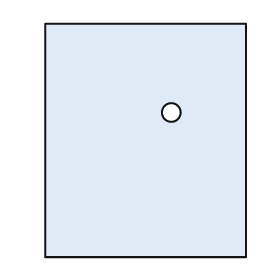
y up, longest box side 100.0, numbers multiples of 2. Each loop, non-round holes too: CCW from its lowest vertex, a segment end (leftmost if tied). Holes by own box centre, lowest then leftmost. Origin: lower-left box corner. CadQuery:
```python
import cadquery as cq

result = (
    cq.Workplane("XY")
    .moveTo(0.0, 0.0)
    .lineTo(86.0, 0.0)
    .lineTo(86.0, 100.0)
    .lineTo(0.0, 100.0)
    .close()
    .moveTo(54.0, 62.0)
    .circle(4.0)
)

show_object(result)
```